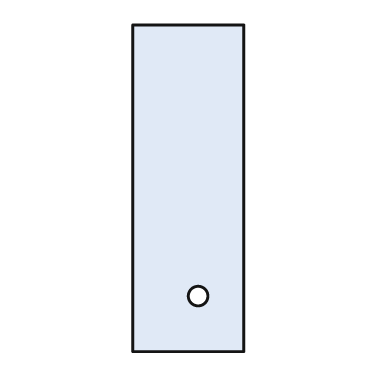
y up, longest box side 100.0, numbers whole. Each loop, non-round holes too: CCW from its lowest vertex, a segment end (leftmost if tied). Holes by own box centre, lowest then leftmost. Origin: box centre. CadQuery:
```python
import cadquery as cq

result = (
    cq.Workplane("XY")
    .moveTo(-17.0, -50.0)
    .lineTo(17.0, -50.0)
    .lineTo(17.0, 50.0)
    .lineTo(-17.0, 50.0)
    .close()
    .moveTo(3.0, -33.0)
    .circle(3.0)
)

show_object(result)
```